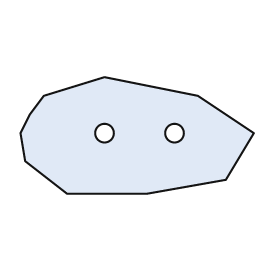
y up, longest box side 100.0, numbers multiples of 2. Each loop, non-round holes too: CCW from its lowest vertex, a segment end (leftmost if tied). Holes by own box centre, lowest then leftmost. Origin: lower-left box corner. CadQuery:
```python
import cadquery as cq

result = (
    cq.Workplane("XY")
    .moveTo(20.0, 0.0)
    .lineTo(54.0, 0.0)
    .lineTo(88.0, 6.0)
    .lineTo(100.0, 26.0)
    .lineTo(76.0, 42.0)
    .lineTo(36.0, 50.0)
    .lineTo(10.0, 42.0)
    .lineTo(4.0, 34.0)
    .lineTo(0.0, 26.0)
    .lineTo(2.0, 14.0)
    .close()
    .moveTo(36.0, 26.0)
    .circle(4.0)
    .moveTo(66.0, 26.0)
    .circle(4.0)
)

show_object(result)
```